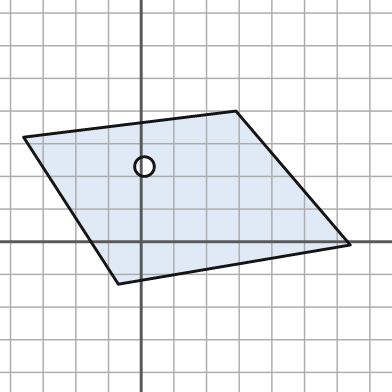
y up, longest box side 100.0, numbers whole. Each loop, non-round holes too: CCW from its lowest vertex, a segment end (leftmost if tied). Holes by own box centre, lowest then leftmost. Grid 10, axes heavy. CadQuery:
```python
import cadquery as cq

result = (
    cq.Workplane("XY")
    .moveTo(-7.0, -13.0)
    .lineTo(64.0, -1.0)
    .lineTo(29.0, 40.0)
    .lineTo(-36.0, 32.0)
    .close()
    .moveTo(1.0, 23.0)
    .circle(3.0)
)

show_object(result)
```